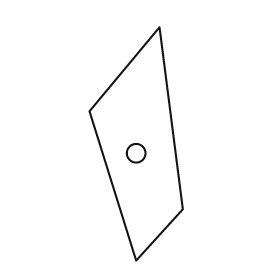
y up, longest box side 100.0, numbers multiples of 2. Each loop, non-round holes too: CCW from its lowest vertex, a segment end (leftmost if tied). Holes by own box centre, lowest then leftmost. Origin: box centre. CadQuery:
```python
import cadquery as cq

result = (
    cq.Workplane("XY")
    .moveTo(0.0, -50.0)
    .lineTo(20.0, -28.0)
    .lineTo(10.0, 50.0)
    .lineTo(-20.0, 14.0)
    .close()
    .moveTo(0.0, -4.0)
    .circle(4.0)
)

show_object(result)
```